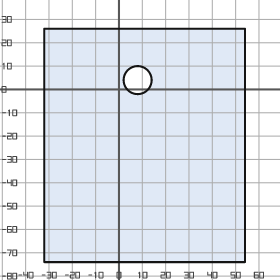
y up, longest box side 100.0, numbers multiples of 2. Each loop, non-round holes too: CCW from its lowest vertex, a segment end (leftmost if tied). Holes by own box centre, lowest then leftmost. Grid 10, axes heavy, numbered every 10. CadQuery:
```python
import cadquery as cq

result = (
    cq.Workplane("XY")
    .moveTo(-32.0, -74.0)
    .lineTo(54.0, -74.0)
    .lineTo(54.0, 26.0)
    .lineTo(-32.0, 26.0)
    .close()
    .moveTo(8.0, 4.0)
    .circle(6.0)
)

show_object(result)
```